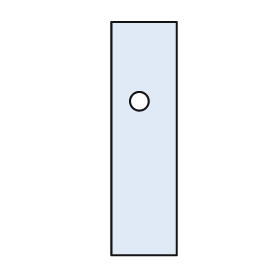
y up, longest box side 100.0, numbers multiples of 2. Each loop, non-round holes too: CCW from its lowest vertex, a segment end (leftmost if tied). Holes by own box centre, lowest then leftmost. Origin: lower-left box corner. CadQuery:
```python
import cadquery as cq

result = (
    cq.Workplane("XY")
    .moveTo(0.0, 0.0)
    .lineTo(28.0, 0.0)
    .lineTo(28.0, 100.0)
    .lineTo(0.0, 100.0)
    .close()
    .moveTo(12.0, 66.0)
    .circle(4.0)
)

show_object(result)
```